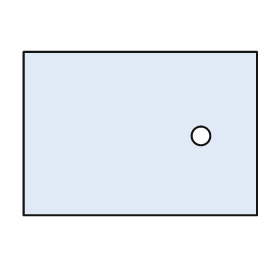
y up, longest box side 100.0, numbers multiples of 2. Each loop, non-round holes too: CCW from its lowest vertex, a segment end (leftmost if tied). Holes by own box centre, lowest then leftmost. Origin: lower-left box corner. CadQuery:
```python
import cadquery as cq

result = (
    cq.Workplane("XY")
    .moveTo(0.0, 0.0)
    .lineTo(100.0, 0.0)
    .lineTo(100.0, 70.0)
    .lineTo(0.0, 70.0)
    .close()
    .moveTo(76.0, 34.0)
    .circle(4.0)
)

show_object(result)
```